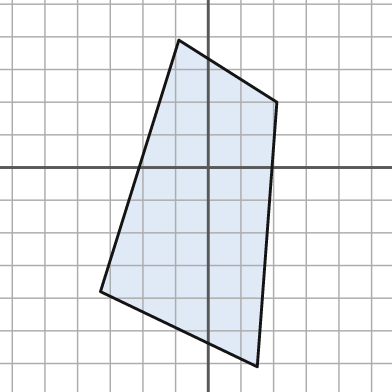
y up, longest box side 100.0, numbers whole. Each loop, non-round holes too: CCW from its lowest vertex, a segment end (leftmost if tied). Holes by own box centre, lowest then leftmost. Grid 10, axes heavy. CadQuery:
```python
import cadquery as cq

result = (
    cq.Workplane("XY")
    .moveTo(15.0, -61.0)
    .lineTo(21.0, 20.0)
    .lineTo(-9.0, 39.0)
    .lineTo(-33.0, -38.0)
    .close()
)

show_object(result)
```